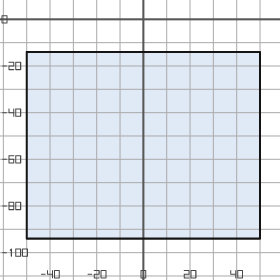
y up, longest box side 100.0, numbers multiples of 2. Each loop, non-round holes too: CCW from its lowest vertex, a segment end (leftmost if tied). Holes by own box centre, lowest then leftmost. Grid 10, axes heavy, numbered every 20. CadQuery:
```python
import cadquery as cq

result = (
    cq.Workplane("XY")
    .moveTo(-50.0, -94.0)
    .lineTo(50.0, -94.0)
    .lineTo(50.0, -14.0)
    .lineTo(-50.0, -14.0)
    .close()
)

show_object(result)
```